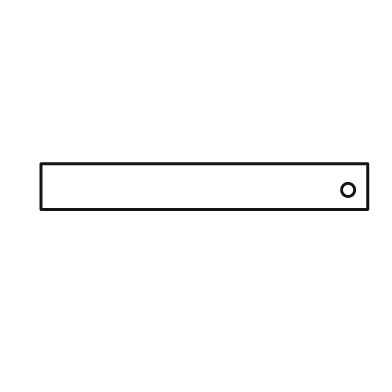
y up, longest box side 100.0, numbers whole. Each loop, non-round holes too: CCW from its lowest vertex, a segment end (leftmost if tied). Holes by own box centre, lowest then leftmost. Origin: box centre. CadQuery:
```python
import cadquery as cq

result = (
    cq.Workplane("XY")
    .moveTo(-50.0, -7.0)
    .lineTo(50.0, -7.0)
    .lineTo(50.0, 7.0)
    .lineTo(-50.0, 7.0)
    .close()
    .moveTo(44.0, -1.0)
    .circle(2.0)
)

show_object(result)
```